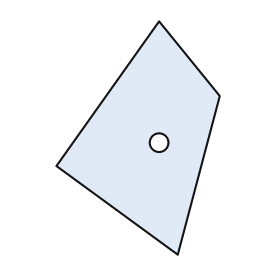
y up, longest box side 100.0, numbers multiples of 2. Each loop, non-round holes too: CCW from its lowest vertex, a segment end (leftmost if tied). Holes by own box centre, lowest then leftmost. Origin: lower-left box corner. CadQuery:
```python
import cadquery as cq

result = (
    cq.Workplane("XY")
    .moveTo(52.0, 0.0)
    .lineTo(70.0, 68.0)
    .lineTo(44.0, 100.0)
    .lineTo(0.0, 38.0)
    .close()
    .moveTo(44.0, 48.0)
    .circle(4.0)
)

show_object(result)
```